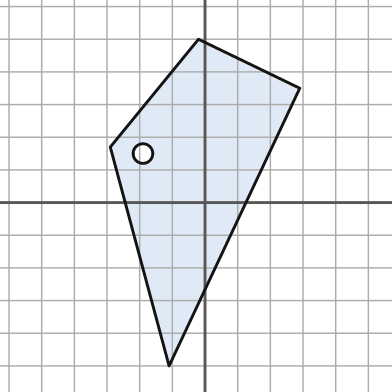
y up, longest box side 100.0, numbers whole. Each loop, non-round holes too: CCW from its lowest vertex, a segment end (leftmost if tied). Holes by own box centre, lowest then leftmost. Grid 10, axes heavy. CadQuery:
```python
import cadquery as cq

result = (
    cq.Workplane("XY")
    .moveTo(-11.0, -50.0)
    .lineTo(29.0, 35.0)
    .lineTo(-2.0, 50.0)
    .lineTo(-29.0, 17.0)
    .close()
    .moveTo(-19.0, 15.0)
    .circle(3.0)
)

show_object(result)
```